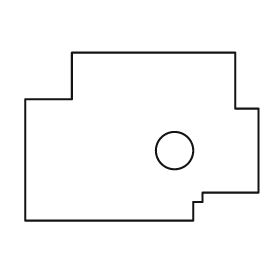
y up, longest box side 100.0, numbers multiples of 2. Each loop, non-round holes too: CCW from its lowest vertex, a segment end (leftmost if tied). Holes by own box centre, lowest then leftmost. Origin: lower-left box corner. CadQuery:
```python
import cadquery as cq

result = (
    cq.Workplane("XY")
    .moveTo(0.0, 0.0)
    .lineTo(72.0, 0.0)
    .lineTo(72.0, 8.0)
    .lineTo(76.0, 8.0)
    .lineTo(76.0, 12.0)
    .lineTo(100.0, 12.0)
    .lineTo(100.0, 48.0)
    .lineTo(90.0, 48.0)
    .lineTo(90.0, 72.0)
    .lineTo(20.0, 72.0)
    .lineTo(20.0, 52.0)
    .lineTo(0.0, 52.0)
    .close()
    .moveTo(64.0, 30.0)
    .circle(8.0)
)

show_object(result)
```